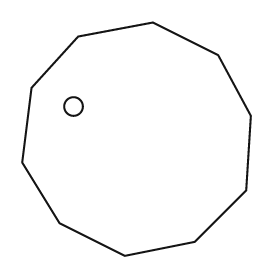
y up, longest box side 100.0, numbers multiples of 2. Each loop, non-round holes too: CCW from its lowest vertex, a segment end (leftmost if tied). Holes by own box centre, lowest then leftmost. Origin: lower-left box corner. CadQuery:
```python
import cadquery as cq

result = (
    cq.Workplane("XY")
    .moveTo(44.0, 0.0)
    .lineTo(74.0, 6.0)
    .lineTo(96.0, 28.0)
    .lineTo(98.0, 60.0)
    .lineTo(84.0, 86.0)
    .lineTo(56.0, 100.0)
    .lineTo(24.0, 94.0)
    .lineTo(4.0, 72.0)
    .lineTo(0.0, 40.0)
    .lineTo(16.0, 14.0)
    .close()
    .moveTo(22.0, 64.0)
    .circle(4.0)
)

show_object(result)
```